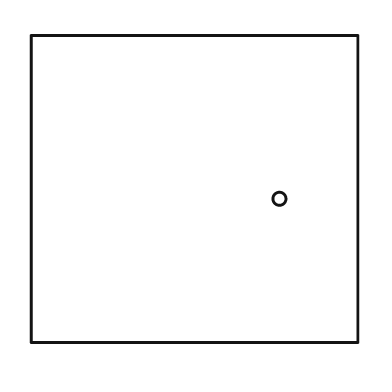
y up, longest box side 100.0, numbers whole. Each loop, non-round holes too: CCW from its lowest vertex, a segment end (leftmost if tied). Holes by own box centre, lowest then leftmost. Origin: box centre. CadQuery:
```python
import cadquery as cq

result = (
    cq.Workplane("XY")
    .moveTo(-50.0, -47.0)
    .lineTo(50.0, -47.0)
    .lineTo(50.0, 47.0)
    .lineTo(-50.0, 47.0)
    .close()
    .moveTo(26.0, -3.0)
    .circle(2.0)
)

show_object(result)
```